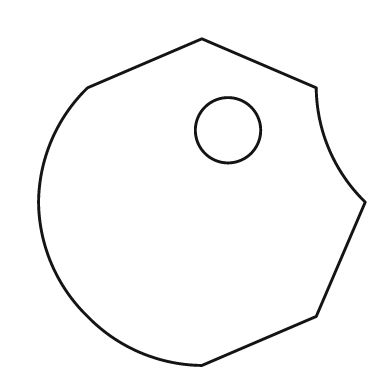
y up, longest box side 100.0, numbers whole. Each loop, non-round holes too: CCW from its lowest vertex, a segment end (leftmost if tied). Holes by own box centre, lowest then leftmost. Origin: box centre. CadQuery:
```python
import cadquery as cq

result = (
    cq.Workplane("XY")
    .moveTo(0.0, -50.0)
    .lineTo(35.0, -35.0)
    .lineTo(50.0, 0.0)
    .threePointArc((39.0, 16.0), (35.0, 35.0))
    .lineTo(0.0, 50.0)
    .lineTo(-35.0, 35.0)
    .threePointArc((-46.0, 19.0), (-50.0, 0.0))
    .threePointArc((-46.0, -19.0), (-35.0, -35.0))
    .threePointArc((-19.0, -46.0), (0.0, -50.0))
    .close()
    .moveTo(8.0, 22.0)
    .circle(10.0)
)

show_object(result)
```